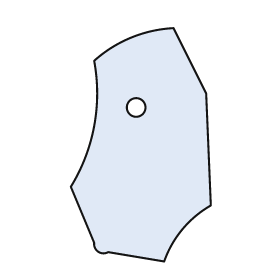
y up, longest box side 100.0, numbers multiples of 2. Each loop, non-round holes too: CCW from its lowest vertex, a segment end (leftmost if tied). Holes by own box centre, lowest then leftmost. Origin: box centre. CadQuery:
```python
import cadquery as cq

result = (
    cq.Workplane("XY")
    .moveTo(10.0, -50.0)
    .threePointArc((18.0, -36.0), (30.0, -26.0))
    .lineTo(28.0, 22.0)
    .lineTo(14.0, 50.0)
    .threePointArc((-4.0, 46.0), (-20.0, 36.0))
    .threePointArc((-20.0, 8.0), (-30.0, -18.0))
    .lineTo(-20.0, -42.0)
    .threePointArc((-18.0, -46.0), (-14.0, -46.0))
    .close()
    .moveTo(-2.0, 16.0)
    .circle(4.0)
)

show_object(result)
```